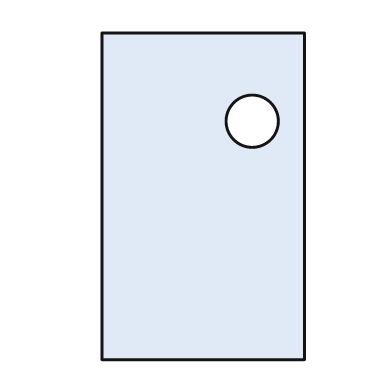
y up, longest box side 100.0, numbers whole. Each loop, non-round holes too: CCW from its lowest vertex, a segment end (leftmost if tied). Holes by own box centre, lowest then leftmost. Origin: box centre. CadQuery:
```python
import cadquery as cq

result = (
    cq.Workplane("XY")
    .moveTo(-31.0, -50.0)
    .lineTo(31.0, -50.0)
    .lineTo(31.0, 50.0)
    .lineTo(-31.0, 50.0)
    .close()
    .moveTo(15.0, 23.0)
    .circle(8.0)
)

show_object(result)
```